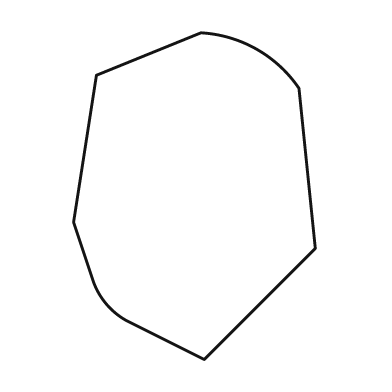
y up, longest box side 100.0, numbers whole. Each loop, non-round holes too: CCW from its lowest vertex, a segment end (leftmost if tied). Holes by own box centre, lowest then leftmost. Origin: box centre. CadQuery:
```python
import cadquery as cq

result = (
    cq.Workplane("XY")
    .moveTo(3.0, -50.0)
    .lineTo(37.0, -16.0)
    .lineTo(32.0, 33.0)
    .threePointArc((19.0, 45.0), (2.0, 50.0))
    .lineTo(-30.0, 37.0)
    .lineTo(-37.0, -8.0)
    .lineTo(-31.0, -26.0)
    .threePointArc((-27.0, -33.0), (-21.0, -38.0))
    .close()
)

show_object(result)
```